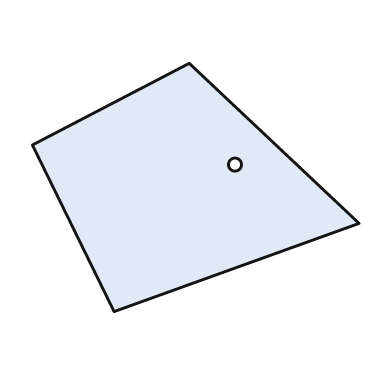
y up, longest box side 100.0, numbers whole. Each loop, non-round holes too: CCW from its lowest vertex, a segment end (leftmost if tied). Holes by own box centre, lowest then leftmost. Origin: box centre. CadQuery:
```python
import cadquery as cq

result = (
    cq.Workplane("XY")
    .moveTo(-25.0, -38.0)
    .lineTo(50.0, -11.0)
    .lineTo(-2.0, 38.0)
    .lineTo(-50.0, 13.0)
    .close()
    .moveTo(12.0, 7.0)
    .circle(2.0)
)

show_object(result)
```